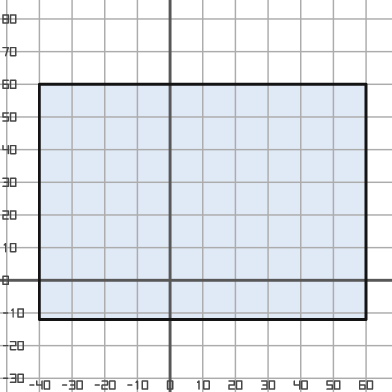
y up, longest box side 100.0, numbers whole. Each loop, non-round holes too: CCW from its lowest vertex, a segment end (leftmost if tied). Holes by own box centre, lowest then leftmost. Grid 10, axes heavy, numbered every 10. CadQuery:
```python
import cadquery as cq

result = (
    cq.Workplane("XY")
    .moveTo(-40.0, -12.0)
    .lineTo(60.0, -12.0)
    .lineTo(60.0, 60.0)
    .lineTo(-40.0, 60.0)
    .close()
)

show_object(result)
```